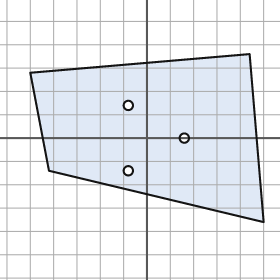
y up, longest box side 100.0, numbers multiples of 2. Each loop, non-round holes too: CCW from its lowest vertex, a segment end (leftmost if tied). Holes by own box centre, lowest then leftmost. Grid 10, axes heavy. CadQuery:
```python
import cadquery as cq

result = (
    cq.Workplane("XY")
    .moveTo(50.0, -36.0)
    .lineTo(44.0, 36.0)
    .lineTo(-50.0, 28.0)
    .lineTo(-42.0, -14.0)
    .close()
    .moveTo(-8.0, -14.0)
    .circle(2.0)
    .moveTo(16.0, 0.0)
    .circle(2.0)
    .moveTo(-8.0, 14.0)
    .circle(2.0)
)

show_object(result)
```